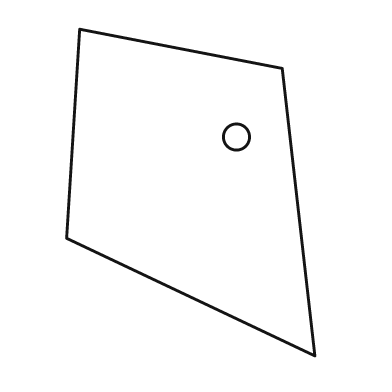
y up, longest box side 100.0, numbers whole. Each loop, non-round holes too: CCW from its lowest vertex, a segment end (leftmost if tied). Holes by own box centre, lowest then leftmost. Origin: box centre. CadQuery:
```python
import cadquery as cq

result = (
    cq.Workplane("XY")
    .moveTo(38.0, -50.0)
    .lineTo(28.0, 38.0)
    .lineTo(-34.0, 50.0)
    .lineTo(-38.0, -14.0)
    .close()
    .moveTo(14.0, 17.0)
    .circle(4.0)
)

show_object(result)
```